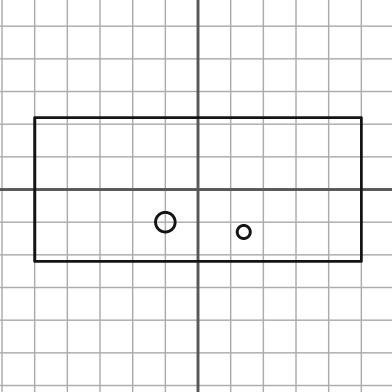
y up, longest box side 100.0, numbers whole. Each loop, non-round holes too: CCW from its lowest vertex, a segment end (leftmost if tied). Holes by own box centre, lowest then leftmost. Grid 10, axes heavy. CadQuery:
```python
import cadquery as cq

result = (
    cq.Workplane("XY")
    .moveTo(-50.0, -22.0)
    .lineTo(50.0, -22.0)
    .lineTo(50.0, 22.0)
    .lineTo(-50.0, 22.0)
    .close()
    .moveTo(14.0, -13.0)
    .circle(2.0)
    .moveTo(-10.0, -10.0)
    .circle(3.0)
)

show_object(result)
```